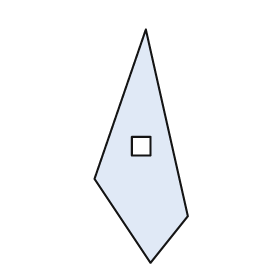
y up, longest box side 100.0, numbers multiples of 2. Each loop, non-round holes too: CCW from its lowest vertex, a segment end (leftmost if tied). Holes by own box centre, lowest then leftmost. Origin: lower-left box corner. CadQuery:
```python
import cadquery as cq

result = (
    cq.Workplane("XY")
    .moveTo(24.0, 0.0)
    .lineTo(40.0, 20.0)
    .lineTo(22.0, 100.0)
    .lineTo(0.0, 36.0)
    .close()
    .moveTo(16.0, 46.0)
    .lineTo(24.0, 46.0)
    .lineTo(24.0, 54.0)
    .lineTo(16.0, 54.0)
    .close()
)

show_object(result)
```